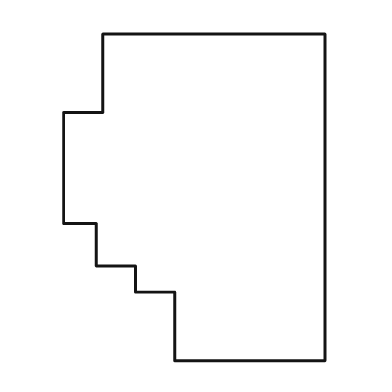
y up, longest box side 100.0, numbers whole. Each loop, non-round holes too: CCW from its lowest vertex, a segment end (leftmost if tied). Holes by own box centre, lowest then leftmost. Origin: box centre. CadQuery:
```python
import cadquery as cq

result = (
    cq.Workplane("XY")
    .moveTo(-6.0, -50.0)
    .lineTo(40.0, -50.0)
    .lineTo(40.0, 50.0)
    .lineTo(-28.0, 50.0)
    .lineTo(-28.0, 26.0)
    .lineTo(-40.0, 26.0)
    .lineTo(-40.0, -8.0)
    .lineTo(-30.0, -8.0)
    .lineTo(-30.0, -21.0)
    .lineTo(-18.0, -21.0)
    .lineTo(-18.0, -29.0)
    .lineTo(-6.0, -29.0)
    .close()
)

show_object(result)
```